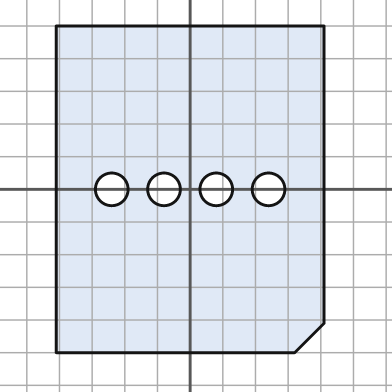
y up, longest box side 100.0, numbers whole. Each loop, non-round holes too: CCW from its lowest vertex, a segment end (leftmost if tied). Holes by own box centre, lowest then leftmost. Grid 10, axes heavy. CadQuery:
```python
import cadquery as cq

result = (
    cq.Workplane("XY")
    .moveTo(-41.0, -50.0)
    .lineTo(32.0, -50.0)
    .lineTo(41.0, -41.0)
    .lineTo(41.0, 50.0)
    .lineTo(-41.0, 50.0)
    .close()
    .moveTo(-24.0, 0.0)
    .circle(5.0)
    .moveTo(-8.0, 0.0)
    .circle(5.0)
    .moveTo(8.0, 0.0)
    .circle(5.0)
    .moveTo(24.0, 0.0)
    .circle(5.0)
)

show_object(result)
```